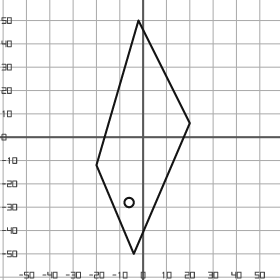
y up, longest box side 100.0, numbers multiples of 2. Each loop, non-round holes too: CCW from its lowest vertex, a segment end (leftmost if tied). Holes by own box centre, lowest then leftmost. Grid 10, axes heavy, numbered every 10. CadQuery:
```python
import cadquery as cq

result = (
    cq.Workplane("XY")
    .moveTo(-4.0, -50.0)
    .lineTo(20.0, 6.0)
    .lineTo(-2.0, 50.0)
    .lineTo(-20.0, -12.0)
    .close()
    .moveTo(-6.0, -28.0)
    .circle(2.0)
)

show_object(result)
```